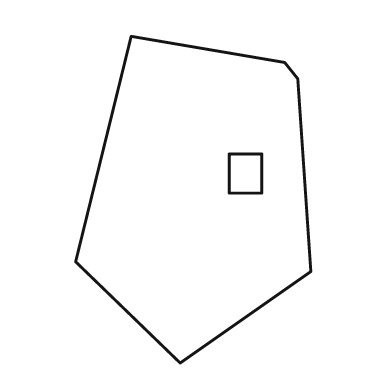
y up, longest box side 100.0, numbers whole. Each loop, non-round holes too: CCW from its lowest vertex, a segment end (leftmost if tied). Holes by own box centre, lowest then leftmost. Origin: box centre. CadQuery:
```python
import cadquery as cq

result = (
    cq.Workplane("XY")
    .moveTo(-4.0, -50.0)
    .lineTo(36.0, -22.0)
    .lineTo(32.0, 37.0)
    .lineTo(28.0, 42.0)
    .lineTo(-19.0, 50.0)
    .lineTo(-36.0, -19.0)
    .close()
    .moveTo(11.0, 2.0)
    .lineTo(21.0, 2.0)
    .lineTo(21.0, 14.0)
    .lineTo(11.0, 14.0)
    .close()
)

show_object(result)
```